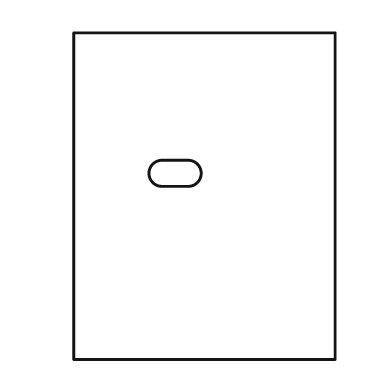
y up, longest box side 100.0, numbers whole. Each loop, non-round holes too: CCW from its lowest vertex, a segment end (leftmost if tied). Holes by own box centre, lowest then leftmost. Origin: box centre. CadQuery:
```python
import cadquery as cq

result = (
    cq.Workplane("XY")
    .moveTo(-40.0, -50.0)
    .lineTo(40.0, -50.0)
    .lineTo(40.0, 50.0)
    .lineTo(-40.0, 50.0)
    .close()
    .moveTo(-13.0, 3.0)
    .lineTo(-5.0, 3.0)
    .threePointArc((-1.0, 7.0), (-5.0, 11.0))
    .lineTo(-13.0, 11.0)
    .threePointArc((-17.0, 7.0), (-13.0, 3.0))
    .close()
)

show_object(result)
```